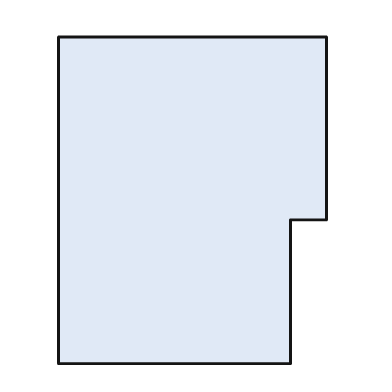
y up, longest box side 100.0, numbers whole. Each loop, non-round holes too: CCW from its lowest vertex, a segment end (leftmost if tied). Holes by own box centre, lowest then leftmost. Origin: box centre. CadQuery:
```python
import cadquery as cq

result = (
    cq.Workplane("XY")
    .moveTo(-41.0, -50.0)
    .lineTo(30.0, -50.0)
    .lineTo(30.0, -6.0)
    .lineTo(41.0, -6.0)
    .lineTo(41.0, 50.0)
    .lineTo(-41.0, 50.0)
    .close()
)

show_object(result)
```